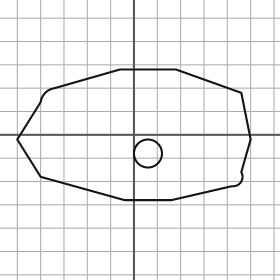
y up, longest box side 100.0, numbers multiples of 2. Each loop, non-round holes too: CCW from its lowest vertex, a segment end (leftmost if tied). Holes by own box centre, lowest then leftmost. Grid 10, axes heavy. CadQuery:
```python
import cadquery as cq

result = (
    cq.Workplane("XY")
    .moveTo(-4.0, -28.0)
    .lineTo(16.0, -28.0)
    .lineTo(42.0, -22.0)
    .threePointArc((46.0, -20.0), (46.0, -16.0))
    .lineTo(50.0, -2.0)
    .lineTo(46.0, 18.0)
    .lineTo(18.0, 28.0)
    .lineTo(-6.0, 28.0)
    .lineTo(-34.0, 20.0)
    .threePointArc((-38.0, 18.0), (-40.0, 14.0))
    .lineTo(-50.0, -2.0)
    .lineTo(-40.0, -18.0)
    .close()
    .moveTo(6.0, -8.0)
    .circle(6.0)
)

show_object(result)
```